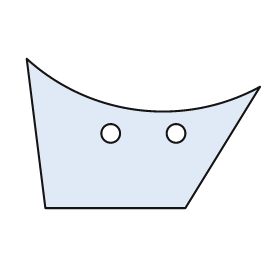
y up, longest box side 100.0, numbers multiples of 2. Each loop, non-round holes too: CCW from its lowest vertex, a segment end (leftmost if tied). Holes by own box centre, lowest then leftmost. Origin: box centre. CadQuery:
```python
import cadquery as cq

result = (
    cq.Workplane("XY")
    .moveTo(-42.0, -32.0)
    .lineTo(18.0, -32.0)
    .lineTo(50.0, 20.0)
    .threePointArc((-2.0, 10.0), (-50.0, 32.0))
    .close()
    .moveTo(-14.0, 0.0)
    .circle(4.0)
    .moveTo(14.0, 0.0)
    .circle(4.0)
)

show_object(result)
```